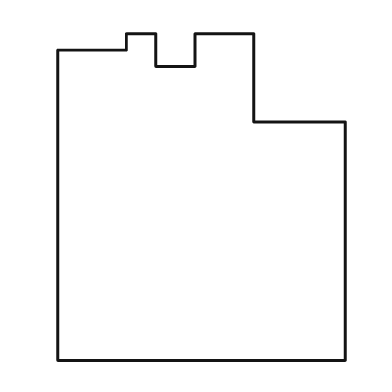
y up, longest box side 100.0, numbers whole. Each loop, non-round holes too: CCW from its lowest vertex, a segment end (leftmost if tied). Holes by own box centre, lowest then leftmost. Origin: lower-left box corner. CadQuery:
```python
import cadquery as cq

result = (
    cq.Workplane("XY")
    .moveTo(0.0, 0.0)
    .lineTo(88.0, 0.0)
    .lineTo(88.0, 73.0)
    .lineTo(60.0, 73.0)
    .lineTo(60.0, 100.0)
    .lineTo(42.0, 100.0)
    .lineTo(42.0, 90.0)
    .lineTo(30.0, 90.0)
    .lineTo(30.0, 100.0)
    .lineTo(21.0, 100.0)
    .lineTo(21.0, 95.0)
    .lineTo(0.0, 95.0)
    .close()
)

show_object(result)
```